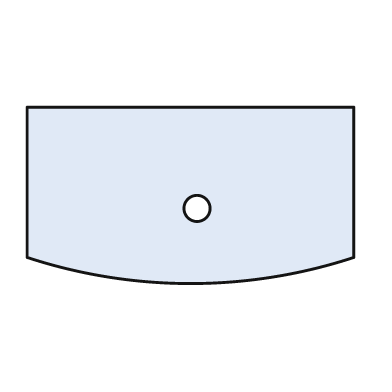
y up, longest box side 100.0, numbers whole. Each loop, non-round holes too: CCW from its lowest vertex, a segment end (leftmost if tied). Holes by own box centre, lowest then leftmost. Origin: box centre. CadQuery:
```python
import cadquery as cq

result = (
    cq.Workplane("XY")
    .moveTo(-50.0, -19.0)
    .threePointArc((0.0, -27.0), (50.0, -19.0))
    .lineTo(50.0, 27.0)
    .lineTo(-50.0, 27.0)
    .close()
    .moveTo(2.0, -4.0)
    .circle(4.0)
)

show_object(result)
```